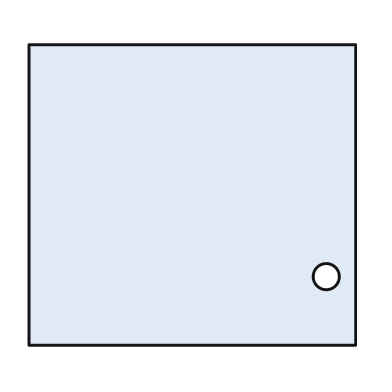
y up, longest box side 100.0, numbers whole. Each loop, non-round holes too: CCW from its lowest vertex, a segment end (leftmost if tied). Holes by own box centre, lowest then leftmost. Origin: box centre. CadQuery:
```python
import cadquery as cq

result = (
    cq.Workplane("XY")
    .moveTo(-50.0, -46.0)
    .lineTo(50.0, -46.0)
    .lineTo(50.0, 46.0)
    .lineTo(-50.0, 46.0)
    .close()
    .moveTo(41.0, -25.0)
    .circle(4.0)
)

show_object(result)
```